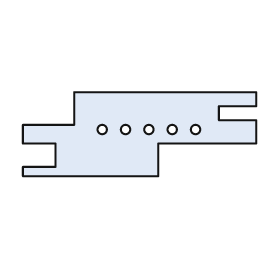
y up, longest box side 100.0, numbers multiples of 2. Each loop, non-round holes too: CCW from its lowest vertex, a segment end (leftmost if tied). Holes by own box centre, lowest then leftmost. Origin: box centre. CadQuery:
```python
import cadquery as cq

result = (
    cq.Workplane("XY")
    .moveTo(-50.0, -18.0)
    .lineTo(8.0, -18.0)
    .lineTo(8.0, -4.0)
    .lineTo(50.0, -4.0)
    .lineTo(50.0, 6.0)
    .lineTo(34.0, 6.0)
    .lineTo(34.0, 12.0)
    .lineTo(50.0, 12.0)
    .lineTo(50.0, 18.0)
    .lineTo(-28.0, 18.0)
    .lineTo(-28.0, 4.0)
    .lineTo(-50.0, 4.0)
    .lineTo(-50.0, -4.0)
    .lineTo(-36.0, -4.0)
    .lineTo(-36.0, -14.0)
    .lineTo(-50.0, -14.0)
    .close()
    .moveTo(-16.0, 2.0)
    .circle(2.0)
    .moveTo(-6.0, 2.0)
    .circle(2.0)
    .moveTo(4.0, 2.0)
    .circle(2.0)
    .moveTo(14.0, 2.0)
    .circle(2.0)
    .moveTo(24.0, 2.0)
    .circle(2.0)
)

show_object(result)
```